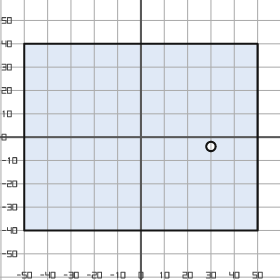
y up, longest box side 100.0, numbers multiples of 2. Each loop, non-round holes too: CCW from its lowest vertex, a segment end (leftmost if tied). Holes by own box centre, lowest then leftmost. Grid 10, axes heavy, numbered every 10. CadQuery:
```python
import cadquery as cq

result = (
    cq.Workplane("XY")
    .moveTo(-50.0, -40.0)
    .lineTo(50.0, -40.0)
    .lineTo(50.0, 40.0)
    .lineTo(-50.0, 40.0)
    .close()
    .moveTo(30.0, -4.0)
    .circle(2.0)
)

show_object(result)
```